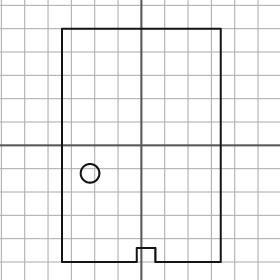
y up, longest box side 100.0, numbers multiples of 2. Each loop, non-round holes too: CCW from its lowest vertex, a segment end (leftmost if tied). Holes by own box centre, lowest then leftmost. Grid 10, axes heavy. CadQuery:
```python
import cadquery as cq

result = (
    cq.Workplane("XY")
    .moveTo(-34.0, -50.0)
    .lineTo(-2.0, -50.0)
    .lineTo(-2.0, -44.0)
    .lineTo(6.0, -44.0)
    .lineTo(6.0, -50.0)
    .lineTo(34.0, -50.0)
    .lineTo(34.0, 50.0)
    .lineTo(-34.0, 50.0)
    .close()
    .moveTo(-22.0, -12.0)
    .circle(4.0)
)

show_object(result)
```